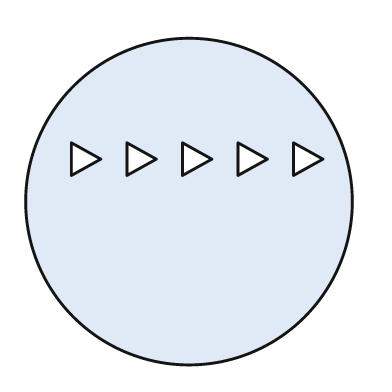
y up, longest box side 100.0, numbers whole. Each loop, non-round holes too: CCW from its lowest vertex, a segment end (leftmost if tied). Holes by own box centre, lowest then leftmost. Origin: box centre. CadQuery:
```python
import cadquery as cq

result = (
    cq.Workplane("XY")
    .moveTo(0.0, 0.0)
    .circle(50.0)
    .moveTo(-36.0, 8.0)
    .lineTo(-27.0, 13.0)
    .lineTo(-36.0, 18.0)
    .close()
    .moveTo(-19.0, 8.0)
    .lineTo(-10.0, 13.0)
    .lineTo(-19.0, 18.0)
    .close()
    .moveTo(-2.0, 8.0)
    .lineTo(7.0, 13.0)
    .lineTo(-2.0, 18.0)
    .close()
    .moveTo(15.0, 8.0)
    .lineTo(24.0, 13.0)
    .lineTo(15.0, 18.0)
    .close()
    .moveTo(32.0, 8.0)
    .lineTo(41.0, 13.0)
    .lineTo(32.0, 18.0)
    .close()
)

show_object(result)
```